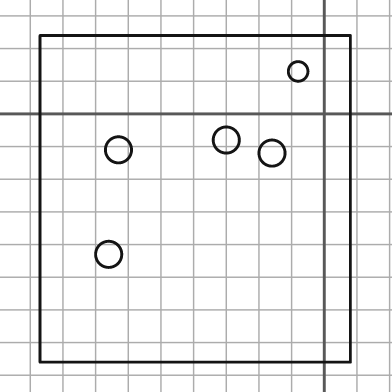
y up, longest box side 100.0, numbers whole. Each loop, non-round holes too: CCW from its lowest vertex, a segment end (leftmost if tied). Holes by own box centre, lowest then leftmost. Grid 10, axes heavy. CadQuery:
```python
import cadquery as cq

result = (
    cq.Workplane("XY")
    .moveTo(-87.0, -76.0)
    .lineTo(8.0, -76.0)
    .lineTo(8.0, 24.0)
    .lineTo(-87.0, 24.0)
    .close()
    .moveTo(-66.0, -43.0)
    .circle(4.0)
    .moveTo(-16.0, -12.0)
    .circle(4.0)
    .moveTo(-63.0, -11.0)
    .circle(4.0)
    .moveTo(-30.0, -8.0)
    .circle(4.0)
    .moveTo(-8.0, 13.0)
    .circle(3.0)
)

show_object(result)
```